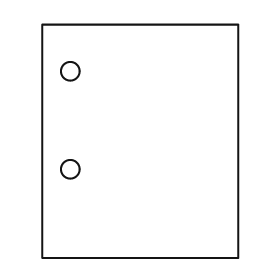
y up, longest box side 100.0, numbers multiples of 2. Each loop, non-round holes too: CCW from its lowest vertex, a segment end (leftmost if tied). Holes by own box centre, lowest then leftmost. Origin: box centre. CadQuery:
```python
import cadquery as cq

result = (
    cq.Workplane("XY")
    .moveTo(-42.0, -50.0)
    .lineTo(42.0, -50.0)
    .lineTo(42.0, 50.0)
    .lineTo(-42.0, 50.0)
    .close()
    .moveTo(-30.0, -12.0)
    .circle(4.0)
    .moveTo(-30.0, 30.0)
    .circle(4.0)
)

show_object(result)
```